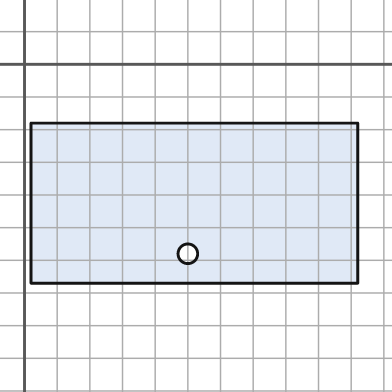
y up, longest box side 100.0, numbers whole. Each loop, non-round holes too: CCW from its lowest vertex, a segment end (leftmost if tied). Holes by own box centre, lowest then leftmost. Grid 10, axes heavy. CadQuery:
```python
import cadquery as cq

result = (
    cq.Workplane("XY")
    .moveTo(2.0, -67.0)
    .lineTo(102.0, -67.0)
    .lineTo(102.0, -18.0)
    .lineTo(2.0, -18.0)
    .close()
    .moveTo(50.0, -58.0)
    .circle(3.0)
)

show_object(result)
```